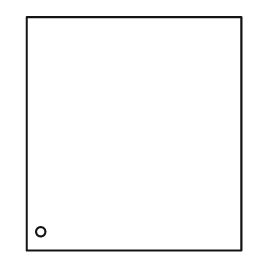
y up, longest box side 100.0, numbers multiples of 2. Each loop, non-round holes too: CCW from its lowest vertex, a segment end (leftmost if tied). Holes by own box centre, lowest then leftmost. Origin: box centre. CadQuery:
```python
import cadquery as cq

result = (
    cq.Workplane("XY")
    .moveTo(-46.0, -50.0)
    .lineTo(46.0, -50.0)
    .lineTo(46.0, 50.0)
    .lineTo(-46.0, 50.0)
    .close()
    .moveTo(-40.0, -42.0)
    .circle(2.0)
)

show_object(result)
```